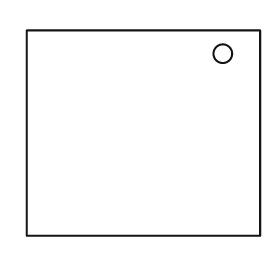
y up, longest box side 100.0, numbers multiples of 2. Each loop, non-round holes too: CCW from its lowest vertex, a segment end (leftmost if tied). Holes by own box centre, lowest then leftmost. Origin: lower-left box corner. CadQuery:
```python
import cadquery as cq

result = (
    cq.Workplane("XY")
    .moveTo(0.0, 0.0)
    .lineTo(100.0, 0.0)
    .lineTo(100.0, 88.0)
    .lineTo(0.0, 88.0)
    .close()
    .moveTo(84.0, 78.0)
    .circle(4.0)
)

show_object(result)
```